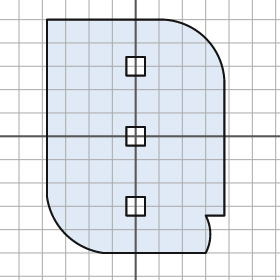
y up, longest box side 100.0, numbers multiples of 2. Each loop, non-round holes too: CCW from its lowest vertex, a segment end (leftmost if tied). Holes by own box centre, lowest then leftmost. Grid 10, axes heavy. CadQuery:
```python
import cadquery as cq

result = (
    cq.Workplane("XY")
    .moveTo(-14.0, -50.0)
    .lineTo(30.0, -50.0)
    .threePointArc((32.0, -42.0), (30.0, -34.0))
    .lineTo(38.0, -34.0)
    .lineTo(38.0, 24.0)
    .threePointArc((30.0, 42.0), (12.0, 50.0))
    .lineTo(-38.0, 50.0)
    .lineTo(-38.0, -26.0)
    .threePointArc((-30.0, -42.0), (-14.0, -50.0))
    .close()
    .moveTo(-4.0, -34.0)
    .lineTo(4.0, -34.0)
    .lineTo(4.0, -26.0)
    .lineTo(-4.0, -26.0)
    .close()
    .moveTo(-4.0, -4.0)
    .lineTo(4.0, -4.0)
    .lineTo(4.0, 4.0)
    .lineTo(-4.0, 4.0)
    .close()
    .moveTo(-4.0, 26.0)
    .lineTo(4.0, 26.0)
    .lineTo(4.0, 34.0)
    .lineTo(-4.0, 34.0)
    .close()
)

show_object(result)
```